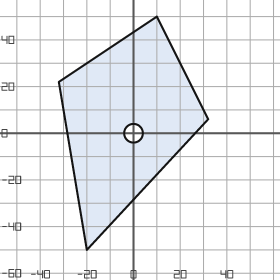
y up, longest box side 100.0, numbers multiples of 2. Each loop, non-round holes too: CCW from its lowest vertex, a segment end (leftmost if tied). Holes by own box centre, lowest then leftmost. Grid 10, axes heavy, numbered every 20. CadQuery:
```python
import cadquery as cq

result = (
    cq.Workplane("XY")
    .moveTo(-20.0, -50.0)
    .lineTo(32.0, 6.0)
    .lineTo(10.0, 50.0)
    .lineTo(-32.0, 22.0)
    .close()
    .moveTo(0.0, 0.0)
    .circle(4.0)
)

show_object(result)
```